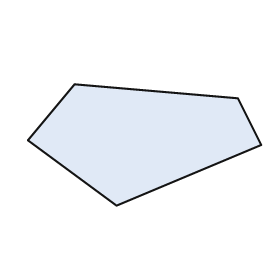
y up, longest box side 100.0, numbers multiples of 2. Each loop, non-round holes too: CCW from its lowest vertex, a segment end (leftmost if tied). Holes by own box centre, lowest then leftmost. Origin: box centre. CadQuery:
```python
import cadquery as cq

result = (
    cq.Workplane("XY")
    .moveTo(-12.0, -26.0)
    .lineTo(50.0, 0.0)
    .lineTo(40.0, 20.0)
    .lineTo(-30.0, 26.0)
    .lineTo(-50.0, 2.0)
    .close()
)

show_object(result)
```